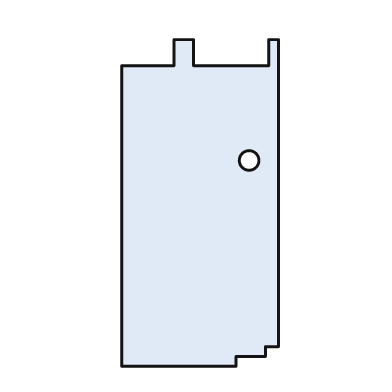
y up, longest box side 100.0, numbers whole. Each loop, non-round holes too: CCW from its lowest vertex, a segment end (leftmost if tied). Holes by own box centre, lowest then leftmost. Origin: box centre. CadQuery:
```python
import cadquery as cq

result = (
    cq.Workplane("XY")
    .moveTo(-24.0, -50.0)
    .lineTo(11.0, -50.0)
    .lineTo(11.0, -47.0)
    .lineTo(20.0, -47.0)
    .lineTo(20.0, -44.0)
    .lineTo(24.0, -44.0)
    .lineTo(24.0, 50.0)
    .lineTo(21.0, 50.0)
    .lineTo(21.0, 42.0)
    .lineTo(-2.0, 42.0)
    .lineTo(-2.0, 50.0)
    .lineTo(-8.0, 50.0)
    .lineTo(-8.0, 42.0)
    .lineTo(-24.0, 42.0)
    .close()
    .moveTo(15.0, 13.0)
    .circle(3.0)
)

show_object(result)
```